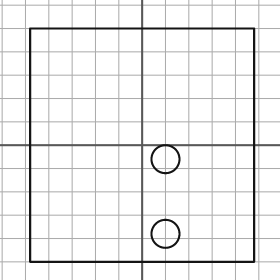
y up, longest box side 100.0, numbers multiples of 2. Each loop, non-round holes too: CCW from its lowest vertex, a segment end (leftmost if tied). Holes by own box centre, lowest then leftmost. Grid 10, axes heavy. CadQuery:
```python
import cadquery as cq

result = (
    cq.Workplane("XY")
    .moveTo(-48.0, -50.0)
    .lineTo(48.0, -50.0)
    .lineTo(48.0, 50.0)
    .lineTo(-48.0, 50.0)
    .close()
    .moveTo(10.0, -38.0)
    .circle(6.0)
    .moveTo(10.0, -6.0)
    .circle(6.0)
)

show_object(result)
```